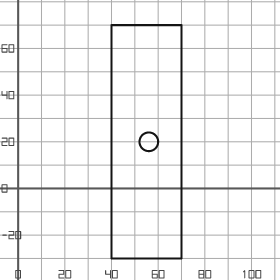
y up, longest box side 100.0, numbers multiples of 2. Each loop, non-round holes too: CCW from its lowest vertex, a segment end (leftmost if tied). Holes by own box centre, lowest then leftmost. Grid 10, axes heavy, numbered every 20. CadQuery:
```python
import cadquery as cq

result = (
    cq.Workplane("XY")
    .moveTo(40.0, -30.0)
    .lineTo(70.0, -30.0)
    .lineTo(70.0, 70.0)
    .lineTo(40.0, 70.0)
    .close()
    .moveTo(56.0, 20.0)
    .circle(4.0)
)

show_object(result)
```